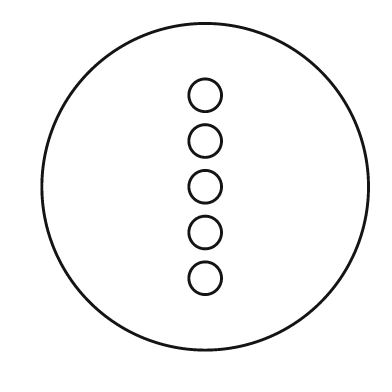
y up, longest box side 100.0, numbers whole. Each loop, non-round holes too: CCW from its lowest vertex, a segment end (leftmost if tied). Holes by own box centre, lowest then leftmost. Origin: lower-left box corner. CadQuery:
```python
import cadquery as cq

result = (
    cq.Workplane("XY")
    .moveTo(50.0, 50.0)
    .circle(50.0)
    .moveTo(50.0, 22.0)
    .circle(5.0)
    .moveTo(50.0, 36.0)
    .circle(5.0)
    .moveTo(50.0, 50.0)
    .circle(5.0)
    .moveTo(50.0, 64.0)
    .circle(5.0)
    .moveTo(50.0, 78.0)
    .circle(5.0)
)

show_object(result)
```